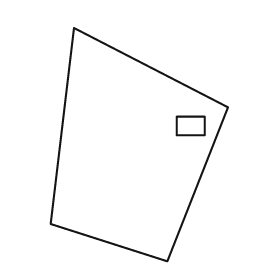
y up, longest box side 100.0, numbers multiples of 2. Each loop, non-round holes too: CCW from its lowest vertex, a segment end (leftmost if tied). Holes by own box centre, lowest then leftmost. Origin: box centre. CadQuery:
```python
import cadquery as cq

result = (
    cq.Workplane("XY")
    .moveTo(12.0, -50.0)
    .lineTo(38.0, 16.0)
    .lineTo(-28.0, 50.0)
    .lineTo(-38.0, -34.0)
    .close()
    .moveTo(16.0, 4.0)
    .lineTo(28.0, 4.0)
    .lineTo(28.0, 12.0)
    .lineTo(16.0, 12.0)
    .close()
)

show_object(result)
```